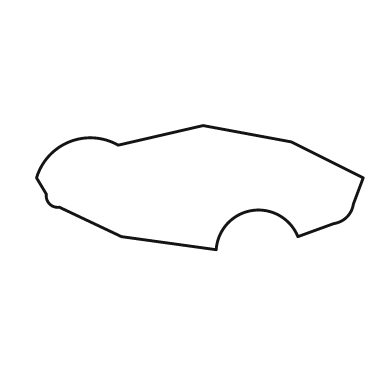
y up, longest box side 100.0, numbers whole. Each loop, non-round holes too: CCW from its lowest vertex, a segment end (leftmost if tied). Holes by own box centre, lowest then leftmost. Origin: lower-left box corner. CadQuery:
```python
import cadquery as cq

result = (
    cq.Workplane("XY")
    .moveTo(55.0, 0.0)
    .threePointArc((66.0, 12.0), (80.0, 4.0))
    .lineTo(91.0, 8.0)
    .threePointArc((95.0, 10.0), (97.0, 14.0))
    .lineTo(100.0, 22.0)
    .lineTo(78.0, 33.0)
    .lineTo(51.0, 38.0)
    .lineTo(25.0, 32.0)
    .threePointArc((10.0, 33.0), (0.0, 22.0))
    .lineTo(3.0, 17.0)
    .threePointArc((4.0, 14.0), (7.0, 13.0))
    .lineTo(26.0, 4.0)
    .close()
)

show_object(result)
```